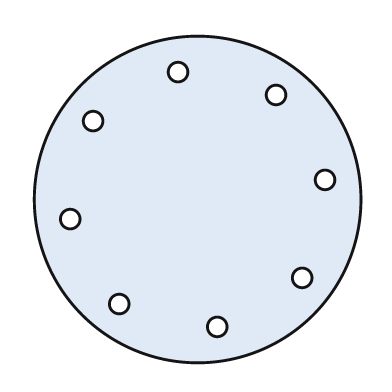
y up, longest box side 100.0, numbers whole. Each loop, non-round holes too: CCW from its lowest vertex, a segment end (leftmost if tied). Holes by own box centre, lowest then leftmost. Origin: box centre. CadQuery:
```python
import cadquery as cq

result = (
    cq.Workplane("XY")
    .moveTo(0.0, 0.0)
    .circle(50.0)
    .moveTo(6.0, -39.0)
    .circle(3.0)
    .moveTo(-24.0, -32.0)
    .circle(3.0)
    .moveTo(32.0, -24.0)
    .circle(3.0)
    .moveTo(-39.0, -6.0)
    .circle(3.0)
    .moveTo(39.0, 6.0)
    .circle(3.0)
    .moveTo(-32.0, 24.0)
    .circle(3.0)
    .moveTo(24.0, 32.0)
    .circle(3.0)
    .moveTo(-6.0, 39.0)
    .circle(3.0)
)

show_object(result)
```